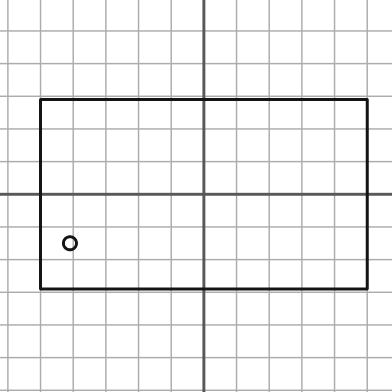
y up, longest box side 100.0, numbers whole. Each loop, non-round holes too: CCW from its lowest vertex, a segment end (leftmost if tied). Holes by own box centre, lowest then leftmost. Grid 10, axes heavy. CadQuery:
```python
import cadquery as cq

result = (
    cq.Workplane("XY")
    .moveTo(-50.0, -29.0)
    .lineTo(50.0, -29.0)
    .lineTo(50.0, 29.0)
    .lineTo(-50.0, 29.0)
    .close()
    .moveTo(-41.0, -15.0)
    .circle(2.0)
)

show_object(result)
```